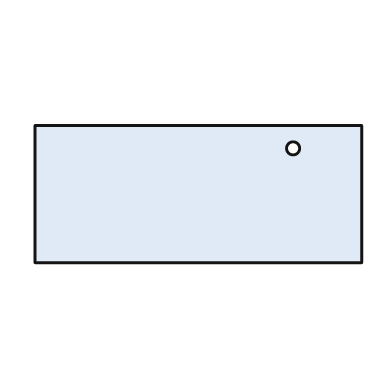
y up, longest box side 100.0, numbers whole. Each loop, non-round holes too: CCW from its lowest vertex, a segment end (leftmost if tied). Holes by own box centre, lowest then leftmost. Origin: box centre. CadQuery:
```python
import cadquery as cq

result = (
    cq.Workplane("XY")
    .moveTo(-50.0, -21.0)
    .lineTo(50.0, -21.0)
    .lineTo(50.0, 21.0)
    .lineTo(-50.0, 21.0)
    .close()
    .moveTo(29.0, 14.0)
    .circle(2.0)
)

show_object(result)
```